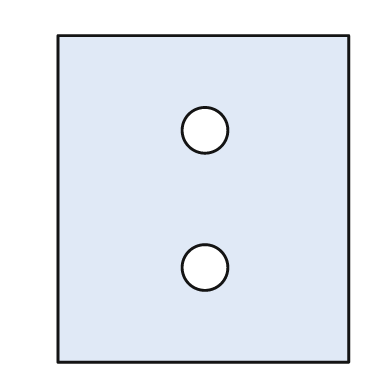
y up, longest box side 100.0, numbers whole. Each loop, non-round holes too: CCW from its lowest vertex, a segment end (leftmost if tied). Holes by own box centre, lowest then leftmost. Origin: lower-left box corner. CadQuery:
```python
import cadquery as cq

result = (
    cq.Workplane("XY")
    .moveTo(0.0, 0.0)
    .lineTo(89.0, 0.0)
    .lineTo(89.0, 100.0)
    .lineTo(0.0, 100.0)
    .close()
    .moveTo(45.0, 29.0)
    .circle(7.0)
    .moveTo(45.0, 71.0)
    .circle(7.0)
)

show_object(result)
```